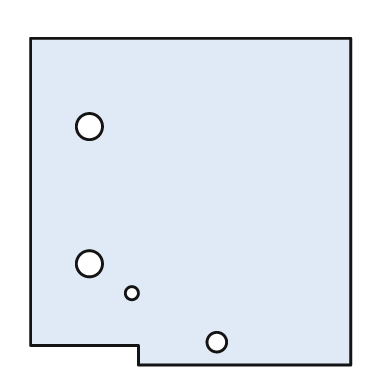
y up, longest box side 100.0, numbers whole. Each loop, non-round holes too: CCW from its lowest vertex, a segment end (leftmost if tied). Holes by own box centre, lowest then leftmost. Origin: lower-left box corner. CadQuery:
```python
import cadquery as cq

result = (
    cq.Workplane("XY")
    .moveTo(33.0, 0.0)
    .lineTo(98.0, 0.0)
    .lineTo(98.0, 100.0)
    .lineTo(0.0, 100.0)
    .lineTo(0.0, 6.0)
    .lineTo(33.0, 6.0)
    .close()
    .moveTo(57.0, 7.0)
    .circle(3.0)
    .moveTo(31.0, 22.0)
    .circle(2.0)
    .moveTo(18.0, 31.0)
    .circle(4.0)
    .moveTo(18.0, 73.0)
    .circle(4.0)
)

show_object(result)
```